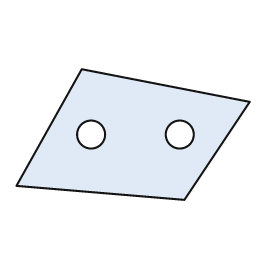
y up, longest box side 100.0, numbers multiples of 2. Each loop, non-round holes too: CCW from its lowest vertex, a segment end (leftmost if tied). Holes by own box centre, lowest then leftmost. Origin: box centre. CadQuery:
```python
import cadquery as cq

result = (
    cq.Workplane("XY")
    .moveTo(22.0, -28.0)
    .lineTo(50.0, 14.0)
    .lineTo(-22.0, 28.0)
    .lineTo(-50.0, -22.0)
    .close()
    .moveTo(-18.0, 0.0)
    .circle(6.0)
    .moveTo(20.0, 0.0)
    .circle(6.0)
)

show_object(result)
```